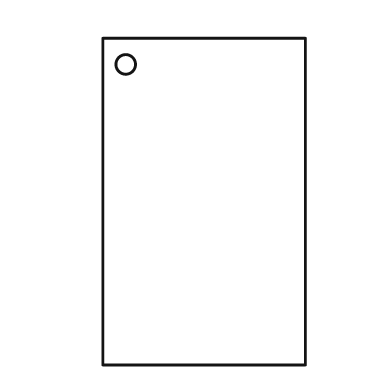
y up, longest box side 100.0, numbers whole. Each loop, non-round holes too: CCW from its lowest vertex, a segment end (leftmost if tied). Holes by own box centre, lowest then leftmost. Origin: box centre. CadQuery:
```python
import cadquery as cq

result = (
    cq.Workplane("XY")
    .moveTo(-31.0, -50.0)
    .lineTo(31.0, -50.0)
    .lineTo(31.0, 50.0)
    .lineTo(-31.0, 50.0)
    .close()
    .moveTo(-24.0, 42.0)
    .circle(3.0)
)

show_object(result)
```